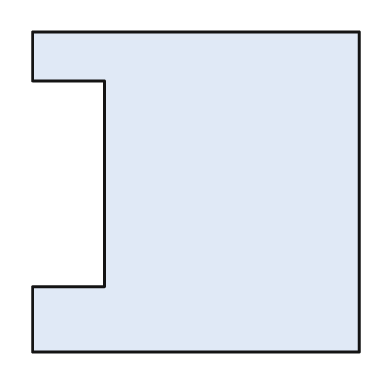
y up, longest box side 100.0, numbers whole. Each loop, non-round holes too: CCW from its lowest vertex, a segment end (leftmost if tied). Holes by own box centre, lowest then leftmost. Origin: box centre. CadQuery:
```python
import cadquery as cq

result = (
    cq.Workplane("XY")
    .moveTo(-50.0, -49.0)
    .lineTo(50.0, -49.0)
    .lineTo(50.0, 49.0)
    .lineTo(-50.0, 49.0)
    .lineTo(-50.0, 34.0)
    .lineTo(-28.0, 34.0)
    .lineTo(-28.0, -29.0)
    .lineTo(-50.0, -29.0)
    .close()
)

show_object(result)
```